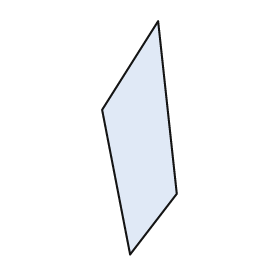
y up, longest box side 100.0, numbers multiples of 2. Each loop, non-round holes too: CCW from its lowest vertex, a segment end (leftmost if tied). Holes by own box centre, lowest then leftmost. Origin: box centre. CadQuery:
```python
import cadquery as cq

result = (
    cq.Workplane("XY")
    .moveTo(-4.0, -50.0)
    .lineTo(16.0, -24.0)
    .lineTo(8.0, 50.0)
    .lineTo(-16.0, 12.0)
    .close()
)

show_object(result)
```